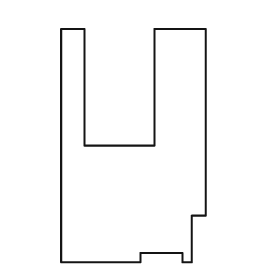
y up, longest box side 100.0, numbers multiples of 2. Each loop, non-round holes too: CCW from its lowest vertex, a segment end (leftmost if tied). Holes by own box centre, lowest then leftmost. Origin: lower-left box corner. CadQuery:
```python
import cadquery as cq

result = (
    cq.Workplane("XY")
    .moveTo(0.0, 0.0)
    .lineTo(34.0, 0.0)
    .lineTo(34.0, 4.0)
    .lineTo(52.0, 4.0)
    .lineTo(52.0, 0.0)
    .lineTo(56.0, 0.0)
    .lineTo(56.0, 20.0)
    .lineTo(62.0, 20.0)
    .lineTo(62.0, 100.0)
    .lineTo(40.0, 100.0)
    .lineTo(40.0, 50.0)
    .lineTo(10.0, 50.0)
    .lineTo(10.0, 100.0)
    .lineTo(0.0, 100.0)
    .close()
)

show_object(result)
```